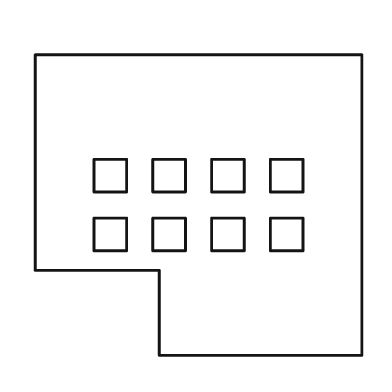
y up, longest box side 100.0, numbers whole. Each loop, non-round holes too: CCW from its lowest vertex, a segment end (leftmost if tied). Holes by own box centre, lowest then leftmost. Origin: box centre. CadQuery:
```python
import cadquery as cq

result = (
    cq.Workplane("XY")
    .moveTo(-12.0, -46.0)
    .lineTo(50.0, -46.0)
    .lineTo(50.0, 46.0)
    .lineTo(-50.0, 46.0)
    .lineTo(-50.0, -20.0)
    .lineTo(-12.0, -20.0)
    .close()
    .moveTo(-32.0, -14.0)
    .lineTo(-22.0, -14.0)
    .lineTo(-22.0, -4.0)
    .lineTo(-32.0, -4.0)
    .close()
    .moveTo(-14.0, -14.0)
    .lineTo(-4.0, -14.0)
    .lineTo(-4.0, -4.0)
    .lineTo(-14.0, -4.0)
    .close()
    .moveTo(4.0, -14.0)
    .lineTo(14.0, -14.0)
    .lineTo(14.0, -4.0)
    .lineTo(4.0, -4.0)
    .close()
    .moveTo(22.0, -14.0)
    .lineTo(32.0, -14.0)
    .lineTo(32.0, -4.0)
    .lineTo(22.0, -4.0)
    .close()
    .moveTo(-32.0, 4.0)
    .lineTo(-22.0, 4.0)
    .lineTo(-22.0, 14.0)
    .lineTo(-32.0, 14.0)
    .close()
    .moveTo(-14.0, 4.0)
    .lineTo(-4.0, 4.0)
    .lineTo(-4.0, 14.0)
    .lineTo(-14.0, 14.0)
    .close()
    .moveTo(4.0, 4.0)
    .lineTo(14.0, 4.0)
    .lineTo(14.0, 14.0)
    .lineTo(4.0, 14.0)
    .close()
    .moveTo(22.0, 4.0)
    .lineTo(32.0, 4.0)
    .lineTo(32.0, 14.0)
    .lineTo(22.0, 14.0)
    .close()
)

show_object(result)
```